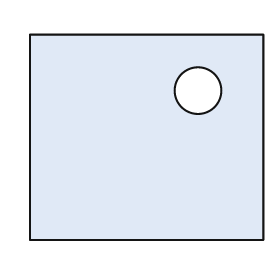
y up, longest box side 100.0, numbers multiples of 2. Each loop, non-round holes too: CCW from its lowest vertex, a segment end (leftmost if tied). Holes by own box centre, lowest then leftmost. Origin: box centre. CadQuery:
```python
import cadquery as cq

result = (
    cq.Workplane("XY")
    .moveTo(-50.0, -44.0)
    .lineTo(50.0, -44.0)
    .lineTo(50.0, 44.0)
    .lineTo(-50.0, 44.0)
    .close()
    .moveTo(22.0, 20.0)
    .circle(10.0)
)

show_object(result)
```